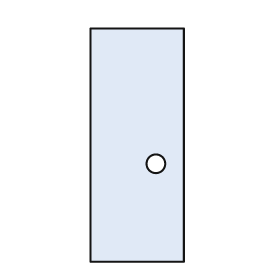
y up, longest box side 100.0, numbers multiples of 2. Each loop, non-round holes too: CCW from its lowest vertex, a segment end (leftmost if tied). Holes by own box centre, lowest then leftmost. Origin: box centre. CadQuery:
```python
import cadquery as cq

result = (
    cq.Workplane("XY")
    .moveTo(-20.0, -50.0)
    .lineTo(20.0, -50.0)
    .lineTo(20.0, 50.0)
    .lineTo(-20.0, 50.0)
    .close()
    .moveTo(8.0, -8.0)
    .circle(4.0)
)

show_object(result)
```